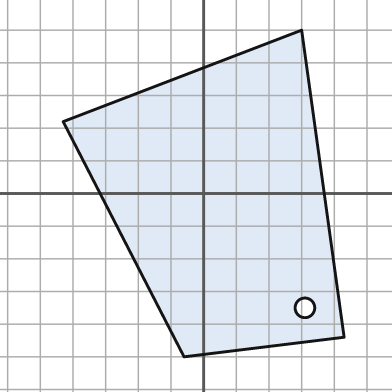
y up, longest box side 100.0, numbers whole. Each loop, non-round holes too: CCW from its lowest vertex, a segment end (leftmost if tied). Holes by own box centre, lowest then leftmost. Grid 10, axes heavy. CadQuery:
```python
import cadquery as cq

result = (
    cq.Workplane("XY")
    .moveTo(-6.0, -50.0)
    .lineTo(43.0, -44.0)
    .lineTo(30.0, 50.0)
    .lineTo(-43.0, 22.0)
    .close()
    .moveTo(31.0, -35.0)
    .circle(3.0)
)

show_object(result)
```